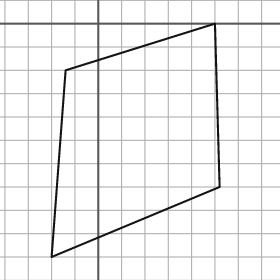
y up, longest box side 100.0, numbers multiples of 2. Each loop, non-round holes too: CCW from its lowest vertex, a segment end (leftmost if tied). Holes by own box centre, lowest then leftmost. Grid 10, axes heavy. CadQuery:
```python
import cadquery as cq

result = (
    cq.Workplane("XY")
    .moveTo(-20.0, -100.0)
    .lineTo(52.0, -70.0)
    .lineTo(50.0, 0.0)
    .lineTo(-14.0, -20.0)
    .close()
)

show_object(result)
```